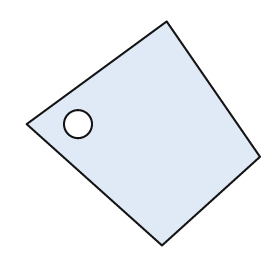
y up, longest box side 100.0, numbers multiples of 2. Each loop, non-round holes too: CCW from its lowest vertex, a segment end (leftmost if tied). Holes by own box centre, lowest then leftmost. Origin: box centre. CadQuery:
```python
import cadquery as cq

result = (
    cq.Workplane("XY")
    .moveTo(8.0, -48.0)
    .lineTo(50.0, -10.0)
    .lineTo(10.0, 48.0)
    .lineTo(-50.0, 4.0)
    .close()
    .moveTo(-28.0, 4.0)
    .circle(6.0)
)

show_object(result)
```